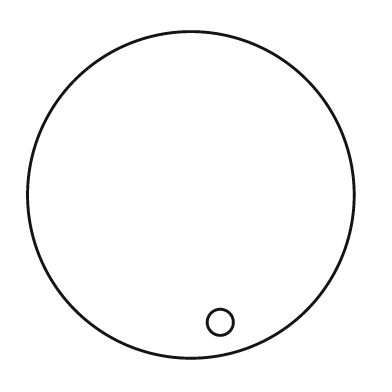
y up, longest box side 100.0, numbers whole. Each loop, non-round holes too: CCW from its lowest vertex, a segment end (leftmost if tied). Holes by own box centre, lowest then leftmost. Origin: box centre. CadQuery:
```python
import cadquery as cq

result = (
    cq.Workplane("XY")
    .moveTo(0.0, 0.0)
    .circle(50.0)
    .moveTo(9.0, -39.0)
    .circle(4.0)
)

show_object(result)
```